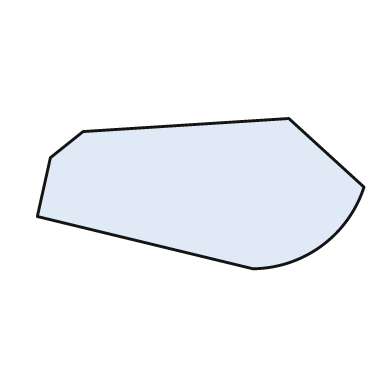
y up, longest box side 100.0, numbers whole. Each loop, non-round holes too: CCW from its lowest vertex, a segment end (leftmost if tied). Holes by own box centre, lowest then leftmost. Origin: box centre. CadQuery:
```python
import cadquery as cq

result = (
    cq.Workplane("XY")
    .moveTo(16.0, -23.0)
    .threePointArc((37.0, -16.0), (50.0, 2.0))
    .lineTo(27.0, 23.0)
    .lineTo(-36.0, 19.0)
    .lineTo(-46.0, 11.0)
    .lineTo(-50.0, -7.0)
    .close()
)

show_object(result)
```